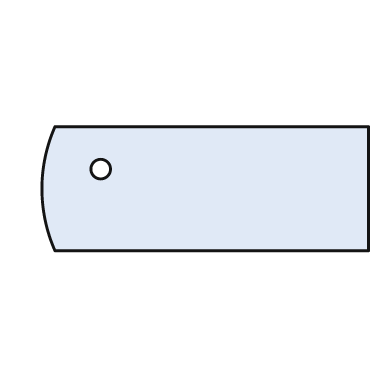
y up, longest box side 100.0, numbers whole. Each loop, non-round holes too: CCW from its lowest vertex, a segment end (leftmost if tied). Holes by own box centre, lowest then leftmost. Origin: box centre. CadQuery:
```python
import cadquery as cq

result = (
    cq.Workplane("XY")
    .moveTo(-46.0, -19.0)
    .lineTo(50.0, -19.0)
    .lineTo(50.0, 19.0)
    .lineTo(-46.0, 19.0)
    .threePointArc((-50.0, 0.0), (-46.0, -19.0))
    .close()
    .moveTo(-32.0, 6.0)
    .circle(3.0)
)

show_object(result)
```